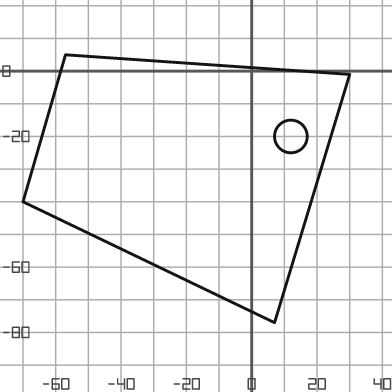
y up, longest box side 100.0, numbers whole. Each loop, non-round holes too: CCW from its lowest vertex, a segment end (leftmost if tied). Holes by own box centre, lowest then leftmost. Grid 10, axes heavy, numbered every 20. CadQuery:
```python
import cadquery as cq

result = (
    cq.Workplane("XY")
    .moveTo(7.0, -77.0)
    .lineTo(30.0, -1.0)
    .lineTo(-57.0, 5.0)
    .lineTo(-70.0, -40.0)
    .close()
    .moveTo(12.0, -20.0)
    .circle(5.0)
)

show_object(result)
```